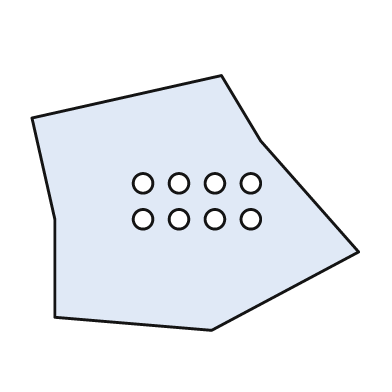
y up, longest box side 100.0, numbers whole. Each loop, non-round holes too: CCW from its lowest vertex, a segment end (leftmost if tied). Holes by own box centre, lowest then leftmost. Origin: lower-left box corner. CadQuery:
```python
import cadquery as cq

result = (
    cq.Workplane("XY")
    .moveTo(55.0, 0.0)
    .lineTo(100.0, 24.0)
    .lineTo(70.0, 58.0)
    .lineTo(58.0, 78.0)
    .lineTo(0.0, 65.0)
    .lineTo(7.0, 34.0)
    .lineTo(7.0, 4.0)
    .close()
    .moveTo(34.0, 34.0)
    .circle(3.0)
    .moveTo(45.0, 34.0)
    .circle(3.0)
    .moveTo(56.0, 34.0)
    .circle(3.0)
    .moveTo(67.0, 34.0)
    .circle(3.0)
    .moveTo(34.0, 45.0)
    .circle(3.0)
    .moveTo(45.0, 45.0)
    .circle(3.0)
    .moveTo(56.0, 45.0)
    .circle(3.0)
    .moveTo(67.0, 45.0)
    .circle(3.0)
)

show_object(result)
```